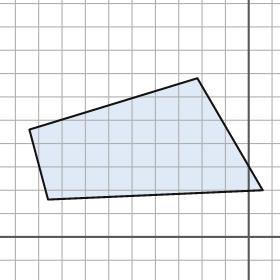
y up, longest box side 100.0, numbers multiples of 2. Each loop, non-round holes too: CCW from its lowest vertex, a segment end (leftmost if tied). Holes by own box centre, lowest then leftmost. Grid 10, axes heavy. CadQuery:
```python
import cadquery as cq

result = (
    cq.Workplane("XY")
    .moveTo(-86.0, 16.0)
    .lineTo(6.0, 20.0)
    .lineTo(-22.0, 68.0)
    .lineTo(-94.0, 46.0)
    .close()
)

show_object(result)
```